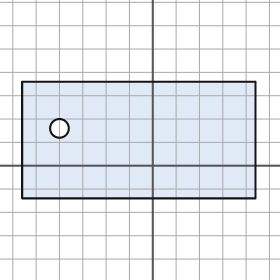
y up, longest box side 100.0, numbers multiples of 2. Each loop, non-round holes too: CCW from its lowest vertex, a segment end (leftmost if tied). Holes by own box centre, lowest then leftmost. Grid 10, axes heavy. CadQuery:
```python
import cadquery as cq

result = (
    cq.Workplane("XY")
    .moveTo(-56.0, -14.0)
    .lineTo(44.0, -14.0)
    .lineTo(44.0, 36.0)
    .lineTo(-56.0, 36.0)
    .close()
    .moveTo(-40.0, 16.0)
    .circle(4.0)
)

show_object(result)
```